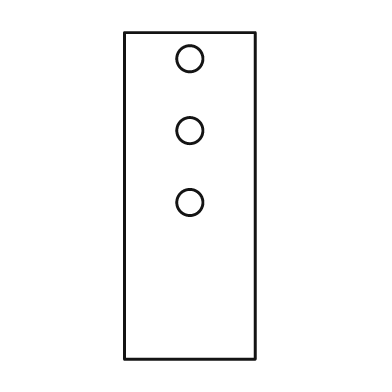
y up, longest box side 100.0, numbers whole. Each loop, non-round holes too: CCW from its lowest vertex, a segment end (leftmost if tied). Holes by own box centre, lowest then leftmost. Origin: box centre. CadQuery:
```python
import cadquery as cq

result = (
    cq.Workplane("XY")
    .moveTo(-20.0, -50.0)
    .lineTo(20.0, -50.0)
    .lineTo(20.0, 50.0)
    .lineTo(-20.0, 50.0)
    .close()
    .moveTo(0.0, -2.0)
    .circle(4.0)
    .moveTo(0.0, 20.0)
    .circle(4.0)
    .moveTo(0.0, 42.0)
    .circle(4.0)
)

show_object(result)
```